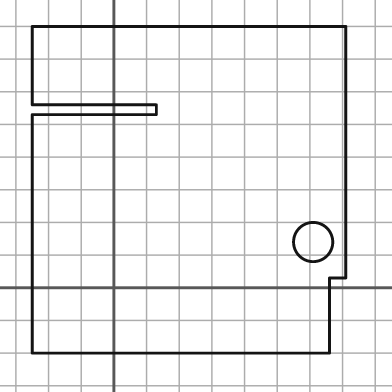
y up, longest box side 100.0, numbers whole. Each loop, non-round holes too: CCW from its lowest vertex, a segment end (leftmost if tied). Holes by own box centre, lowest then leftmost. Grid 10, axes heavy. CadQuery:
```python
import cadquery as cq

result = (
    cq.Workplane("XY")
    .moveTo(-25.0, -20.0)
    .lineTo(66.0, -20.0)
    .lineTo(66.0, 3.0)
    .lineTo(71.0, 3.0)
    .lineTo(71.0, 80.0)
    .lineTo(-25.0, 80.0)
    .lineTo(-25.0, 56.0)
    .lineTo(13.0, 56.0)
    .lineTo(13.0, 53.0)
    .lineTo(-25.0, 53.0)
    .close()
    .moveTo(61.0, 14.0)
    .circle(6.0)
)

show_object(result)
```